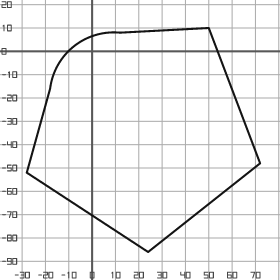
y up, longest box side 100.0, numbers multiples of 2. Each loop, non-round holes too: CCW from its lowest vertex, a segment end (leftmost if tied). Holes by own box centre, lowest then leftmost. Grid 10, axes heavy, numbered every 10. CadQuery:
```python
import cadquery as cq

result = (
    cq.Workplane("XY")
    .moveTo(24.0, -86.0)
    .lineTo(72.0, -48.0)
    .lineTo(50.0, 10.0)
    .lineTo(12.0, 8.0)
    .threePointArc((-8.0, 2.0), (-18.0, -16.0))
    .lineTo(-28.0, -52.0)
    .close()
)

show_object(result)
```